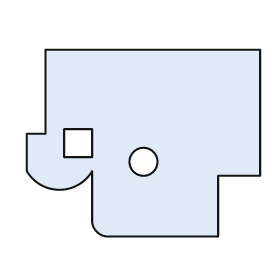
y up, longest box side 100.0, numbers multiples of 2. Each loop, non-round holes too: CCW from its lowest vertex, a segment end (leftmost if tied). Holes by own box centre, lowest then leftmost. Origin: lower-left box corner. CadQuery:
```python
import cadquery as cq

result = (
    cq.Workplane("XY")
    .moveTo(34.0, 0.0)
    .lineTo(82.0, 0.0)
    .lineTo(82.0, 26.0)
    .lineTo(100.0, 26.0)
    .lineTo(100.0, 80.0)
    .lineTo(8.0, 80.0)
    .lineTo(8.0, 44.0)
    .lineTo(0.0, 44.0)
    .lineTo(0.0, 28.0)
    .threePointArc((14.0, 20.0), (28.0, 28.0))
    .lineTo(28.0, 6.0)
    .threePointArc((30.0, 2.0), (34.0, 0.0))
    .close()
    .moveTo(50.0, 32.0)
    .circle(6.0)
    .moveTo(16.0, 34.0)
    .lineTo(28.0, 34.0)
    .lineTo(28.0, 46.0)
    .lineTo(16.0, 46.0)
    .close()
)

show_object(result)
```